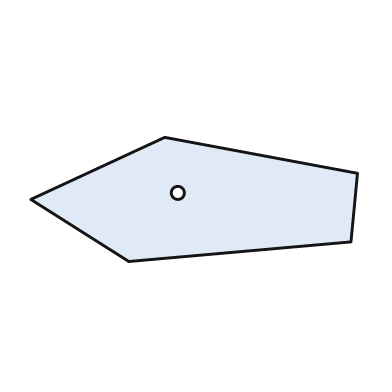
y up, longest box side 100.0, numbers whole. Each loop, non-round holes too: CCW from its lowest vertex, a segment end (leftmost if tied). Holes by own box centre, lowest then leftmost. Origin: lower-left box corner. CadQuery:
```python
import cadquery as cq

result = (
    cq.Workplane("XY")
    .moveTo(30.0, 0.0)
    .lineTo(98.0, 6.0)
    .lineTo(100.0, 27.0)
    .lineTo(41.0, 38.0)
    .lineTo(0.0, 19.0)
    .close()
    .moveTo(45.0, 21.0)
    .circle(2.0)
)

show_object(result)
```